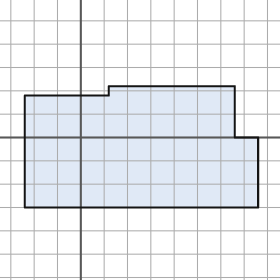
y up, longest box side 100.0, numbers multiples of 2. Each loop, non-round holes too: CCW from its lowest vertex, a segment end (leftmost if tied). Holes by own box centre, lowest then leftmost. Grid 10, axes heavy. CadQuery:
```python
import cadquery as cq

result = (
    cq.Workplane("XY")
    .moveTo(-24.0, -30.0)
    .lineTo(76.0, -30.0)
    .lineTo(76.0, 0.0)
    .lineTo(66.0, 0.0)
    .lineTo(66.0, 22.0)
    .lineTo(12.0, 22.0)
    .lineTo(12.0, 18.0)
    .lineTo(-24.0, 18.0)
    .close()
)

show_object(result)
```